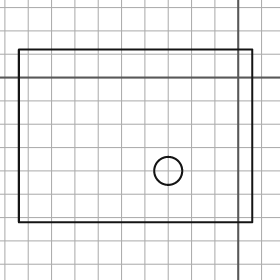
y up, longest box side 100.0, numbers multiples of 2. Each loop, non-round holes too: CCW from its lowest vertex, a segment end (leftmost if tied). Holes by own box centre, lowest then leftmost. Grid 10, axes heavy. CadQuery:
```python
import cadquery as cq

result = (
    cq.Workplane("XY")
    .moveTo(-94.0, -62.0)
    .lineTo(6.0, -62.0)
    .lineTo(6.0, 12.0)
    .lineTo(-94.0, 12.0)
    .close()
    .moveTo(-30.0, -40.0)
    .circle(6.0)
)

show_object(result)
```